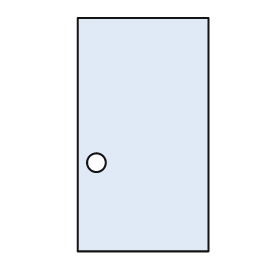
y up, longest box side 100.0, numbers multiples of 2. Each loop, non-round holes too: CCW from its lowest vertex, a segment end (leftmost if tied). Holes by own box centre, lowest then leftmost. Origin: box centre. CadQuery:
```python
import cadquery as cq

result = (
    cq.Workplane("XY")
    .moveTo(-28.0, -50.0)
    .lineTo(28.0, -50.0)
    .lineTo(28.0, 50.0)
    .lineTo(-28.0, 50.0)
    .close()
    .moveTo(-20.0, -12.0)
    .circle(4.0)
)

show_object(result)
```